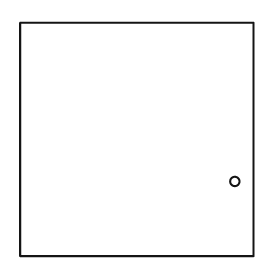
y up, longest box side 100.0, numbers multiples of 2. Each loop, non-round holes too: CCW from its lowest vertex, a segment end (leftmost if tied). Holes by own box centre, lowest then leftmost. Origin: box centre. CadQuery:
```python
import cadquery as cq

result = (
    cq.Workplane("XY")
    .moveTo(-50.0, -50.0)
    .lineTo(50.0, -50.0)
    .lineTo(50.0, 50.0)
    .lineTo(-50.0, 50.0)
    .close()
    .moveTo(42.0, -18.0)
    .circle(2.0)
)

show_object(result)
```